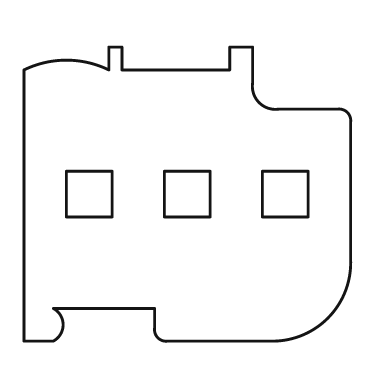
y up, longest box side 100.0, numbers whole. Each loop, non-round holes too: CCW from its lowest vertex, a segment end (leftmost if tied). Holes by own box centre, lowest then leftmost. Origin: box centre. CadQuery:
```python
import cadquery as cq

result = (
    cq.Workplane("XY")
    .moveTo(-50.0, -45.0)
    .lineTo(-41.0, -45.0)
    .threePointArc((-38.0, -40.0), (-41.0, -35.0))
    .lineTo(-10.0, -35.0)
    .lineTo(-10.0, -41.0)
    .threePointArc((-9.0, -44.0), (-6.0, -45.0))
    .lineTo(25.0, -45.0)
    .threePointArc((43.0, -38.0), (50.0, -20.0))
    .lineTo(50.0, 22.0)
    .threePointArc((49.0, 25.0), (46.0, 26.0))
    .lineTo(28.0, 26.0)
    .threePointArc((22.0, 28.0), (20.0, 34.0))
    .lineTo(20.0, 45.0)
    .lineTo(13.0, 45.0)
    .lineTo(13.0, 38.0)
    .lineTo(-20.0, 38.0)
    .lineTo(-20.0, 45.0)
    .lineTo(-24.0, 45.0)
    .lineTo(-24.0, 38.0)
    .threePointArc((-37.0, 41.0), (-50.0, 38.0))
    .close()
    .moveTo(-37.0, -7.0)
    .lineTo(-23.0, -7.0)
    .lineTo(-23.0, 7.0)
    .lineTo(-37.0, 7.0)
    .close()
    .moveTo(-7.0, -7.0)
    .lineTo(7.0, -7.0)
    .lineTo(7.0, 7.0)
    .lineTo(-7.0, 7.0)
    .close()
    .moveTo(23.0, -7.0)
    .lineTo(37.0, -7.0)
    .lineTo(37.0, 7.0)
    .lineTo(23.0, 7.0)
    .close()
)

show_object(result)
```